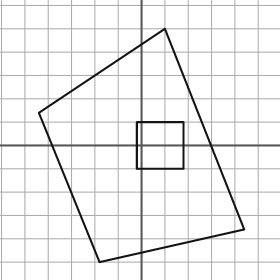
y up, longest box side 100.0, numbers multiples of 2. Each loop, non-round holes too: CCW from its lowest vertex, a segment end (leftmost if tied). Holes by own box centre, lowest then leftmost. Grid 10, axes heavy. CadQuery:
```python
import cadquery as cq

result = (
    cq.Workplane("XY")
    .moveTo(-18.0, -50.0)
    .lineTo(44.0, -36.0)
    .lineTo(10.0, 50.0)
    .lineTo(-44.0, 14.0)
    .close()
    .moveTo(-2.0, -10.0)
    .lineTo(18.0, -10.0)
    .lineTo(18.0, 10.0)
    .lineTo(-2.0, 10.0)
    .close()
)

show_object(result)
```